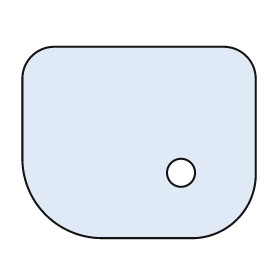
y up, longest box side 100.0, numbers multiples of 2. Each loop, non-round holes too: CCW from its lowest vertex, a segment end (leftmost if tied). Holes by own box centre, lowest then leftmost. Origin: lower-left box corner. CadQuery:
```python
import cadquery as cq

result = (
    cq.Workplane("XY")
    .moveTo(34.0, 0.0)
    .lineTo(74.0, 0.0)
    .threePointArc((92.0, 8.0), (100.0, 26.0))
    .lineTo(100.0, 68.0)
    .threePointArc((96.0, 78.0), (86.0, 82.0))
    .lineTo(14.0, 82.0)
    .threePointArc((4.0, 78.0), (0.0, 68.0))
    .lineTo(0.0, 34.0)
    .threePointArc((10.0, 10.0), (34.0, 0.0))
    .close()
    .moveTo(68.0, 28.0)
    .circle(6.0)
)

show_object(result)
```